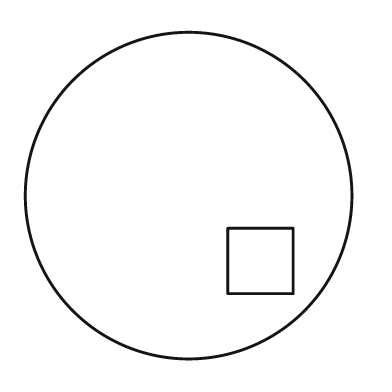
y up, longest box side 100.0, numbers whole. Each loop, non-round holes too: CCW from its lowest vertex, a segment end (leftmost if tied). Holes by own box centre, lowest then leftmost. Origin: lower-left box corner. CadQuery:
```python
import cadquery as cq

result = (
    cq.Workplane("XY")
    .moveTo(50.0, 50.0)
    .circle(50.0)
    .moveTo(62.0, 20.0)
    .lineTo(82.0, 20.0)
    .lineTo(82.0, 40.0)
    .lineTo(62.0, 40.0)
    .close()
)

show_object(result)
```